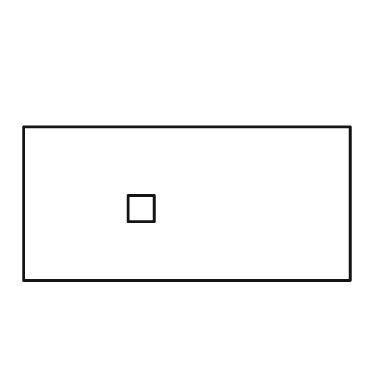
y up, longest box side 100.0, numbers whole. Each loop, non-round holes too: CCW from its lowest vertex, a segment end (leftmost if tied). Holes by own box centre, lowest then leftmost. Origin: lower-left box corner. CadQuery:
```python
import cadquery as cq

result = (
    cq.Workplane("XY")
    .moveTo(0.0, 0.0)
    .lineTo(100.0, 0.0)
    .lineTo(100.0, 47.0)
    .lineTo(0.0, 47.0)
    .close()
    .moveTo(32.0, 18.0)
    .lineTo(40.0, 18.0)
    .lineTo(40.0, 26.0)
    .lineTo(32.0, 26.0)
    .close()
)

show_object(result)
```